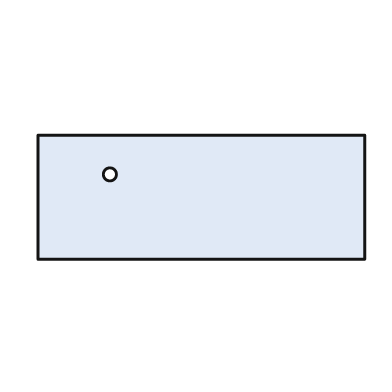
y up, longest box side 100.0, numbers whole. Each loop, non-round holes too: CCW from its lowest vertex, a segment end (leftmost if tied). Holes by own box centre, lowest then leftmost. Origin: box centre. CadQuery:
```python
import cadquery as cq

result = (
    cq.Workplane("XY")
    .moveTo(-50.0, -19.0)
    .lineTo(50.0, -19.0)
    .lineTo(50.0, 19.0)
    .lineTo(-50.0, 19.0)
    .close()
    .moveTo(-28.0, 7.0)
    .circle(2.0)
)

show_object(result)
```